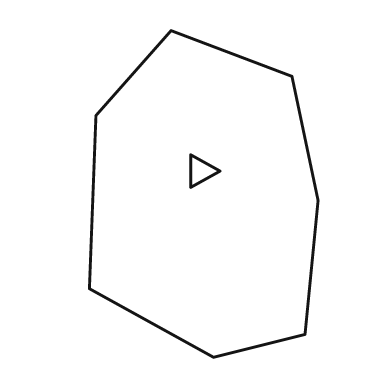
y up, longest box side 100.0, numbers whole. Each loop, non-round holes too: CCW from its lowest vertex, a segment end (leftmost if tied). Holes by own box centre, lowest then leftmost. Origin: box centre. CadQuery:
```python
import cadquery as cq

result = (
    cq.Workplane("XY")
    .moveTo(3.0, -50.0)
    .lineTo(31.0, -43.0)
    .lineTo(35.0, -2.0)
    .lineTo(27.0, 36.0)
    .lineTo(-10.0, 50.0)
    .lineTo(-33.0, 24.0)
    .lineTo(-35.0, -29.0)
    .close()
    .moveTo(-4.0, 2.0)
    .lineTo(5.0, 7.0)
    .lineTo(-4.0, 12.0)
    .close()
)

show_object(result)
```